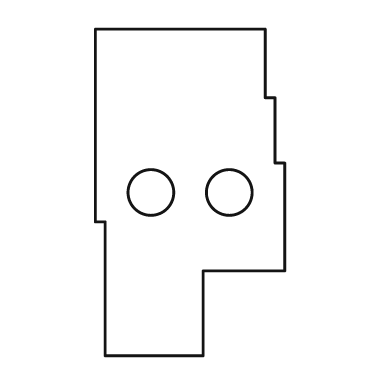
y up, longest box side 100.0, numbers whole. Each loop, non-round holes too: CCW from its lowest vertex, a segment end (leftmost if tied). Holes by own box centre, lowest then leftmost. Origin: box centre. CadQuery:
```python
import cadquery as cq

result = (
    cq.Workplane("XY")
    .moveTo(-26.0, -50.0)
    .lineTo(4.0, -50.0)
    .lineTo(4.0, -24.0)
    .lineTo(29.0, -24.0)
    .lineTo(29.0, 9.0)
    .lineTo(26.0, 9.0)
    .lineTo(26.0, 29.0)
    .lineTo(23.0, 29.0)
    .lineTo(23.0, 50.0)
    .lineTo(-29.0, 50.0)
    .lineTo(-29.0, -9.0)
    .lineTo(-26.0, -9.0)
    .close()
    .moveTo(-12.0, 0.0)
    .circle(7.0)
    .moveTo(12.0, 0.0)
    .circle(7.0)
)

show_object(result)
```